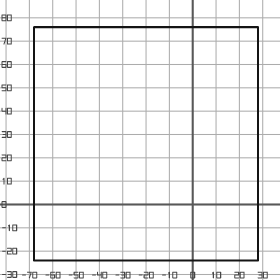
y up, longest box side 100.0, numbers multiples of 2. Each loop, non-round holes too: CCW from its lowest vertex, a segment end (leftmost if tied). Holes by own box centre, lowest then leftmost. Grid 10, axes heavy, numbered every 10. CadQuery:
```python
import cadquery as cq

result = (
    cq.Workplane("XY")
    .moveTo(-68.0, -24.0)
    .lineTo(28.0, -24.0)
    .lineTo(28.0, 76.0)
    .lineTo(-68.0, 76.0)
    .close()
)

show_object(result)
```